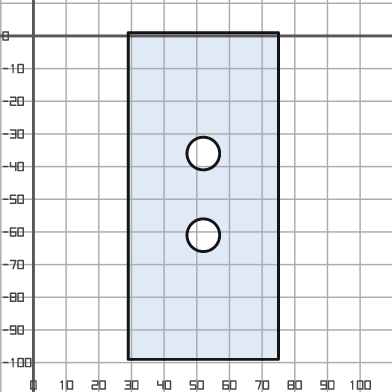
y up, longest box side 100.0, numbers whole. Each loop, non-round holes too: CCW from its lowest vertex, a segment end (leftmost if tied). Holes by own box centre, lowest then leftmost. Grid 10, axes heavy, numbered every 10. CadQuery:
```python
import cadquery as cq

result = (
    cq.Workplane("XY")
    .moveTo(29.0, -99.0)
    .lineTo(75.0, -99.0)
    .lineTo(75.0, 1.0)
    .lineTo(29.0, 1.0)
    .close()
    .moveTo(52.0, -61.0)
    .circle(5.0)
    .moveTo(52.0, -36.0)
    .circle(5.0)
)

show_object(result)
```